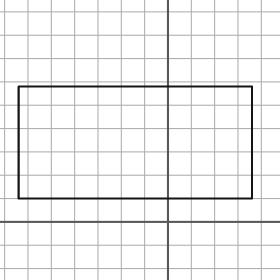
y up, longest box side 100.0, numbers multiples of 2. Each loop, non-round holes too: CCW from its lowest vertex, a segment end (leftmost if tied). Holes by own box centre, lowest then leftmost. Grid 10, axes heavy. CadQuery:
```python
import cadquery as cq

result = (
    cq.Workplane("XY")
    .moveTo(-64.0, 10.0)
    .lineTo(36.0, 10.0)
    .lineTo(36.0, 58.0)
    .lineTo(-64.0, 58.0)
    .close()
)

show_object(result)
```